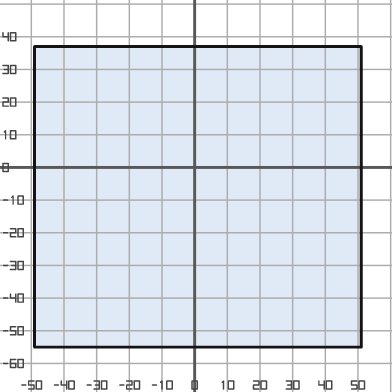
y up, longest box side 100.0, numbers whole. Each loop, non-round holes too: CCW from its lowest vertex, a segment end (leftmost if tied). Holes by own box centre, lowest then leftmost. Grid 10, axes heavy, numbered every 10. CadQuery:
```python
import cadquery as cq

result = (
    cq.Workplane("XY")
    .moveTo(-49.0, -55.0)
    .lineTo(51.0, -55.0)
    .lineTo(51.0, 37.0)
    .lineTo(-49.0, 37.0)
    .close()
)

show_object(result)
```